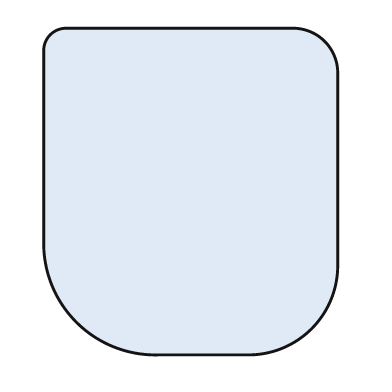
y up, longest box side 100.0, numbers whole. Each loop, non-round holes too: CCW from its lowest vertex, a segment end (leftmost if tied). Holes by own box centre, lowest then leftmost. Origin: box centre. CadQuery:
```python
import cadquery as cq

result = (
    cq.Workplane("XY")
    .moveTo(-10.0, -50.0)
    .lineTo(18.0, -50.0)
    .threePointArc((37.0, -42.0), (45.0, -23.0))
    .lineTo(45.0, 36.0)
    .threePointArc((41.0, 46.0), (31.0, 50.0))
    .lineTo(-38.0, 50.0)
    .threePointArc((-43.0, 48.0), (-45.0, 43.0))
    .lineTo(-45.0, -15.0)
    .threePointArc((-35.0, -40.0), (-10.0, -50.0))
    .close()
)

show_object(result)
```